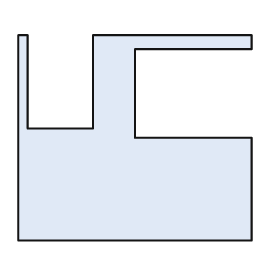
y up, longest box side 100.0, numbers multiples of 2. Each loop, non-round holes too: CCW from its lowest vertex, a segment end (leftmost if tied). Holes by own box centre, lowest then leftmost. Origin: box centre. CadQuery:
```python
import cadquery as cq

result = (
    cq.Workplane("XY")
    .moveTo(-50.0, -44.0)
    .lineTo(50.0, -44.0)
    .lineTo(50.0, 0.0)
    .lineTo(0.0, 0.0)
    .lineTo(0.0, 38.0)
    .lineTo(50.0, 38.0)
    .lineTo(50.0, 44.0)
    .lineTo(-18.0, 44.0)
    .lineTo(-18.0, 4.0)
    .lineTo(-46.0, 4.0)
    .lineTo(-46.0, 44.0)
    .lineTo(-50.0, 44.0)
    .close()
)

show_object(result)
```